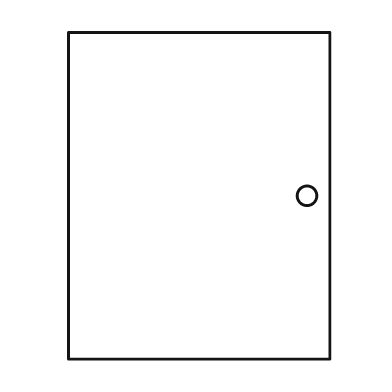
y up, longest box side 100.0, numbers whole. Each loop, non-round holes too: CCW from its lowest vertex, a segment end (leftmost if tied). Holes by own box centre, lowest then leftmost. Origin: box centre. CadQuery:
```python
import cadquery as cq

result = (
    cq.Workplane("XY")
    .moveTo(-40.0, -50.0)
    .lineTo(40.0, -50.0)
    .lineTo(40.0, 50.0)
    .lineTo(-40.0, 50.0)
    .close()
    .moveTo(33.0, 0.0)
    .circle(3.0)
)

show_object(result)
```